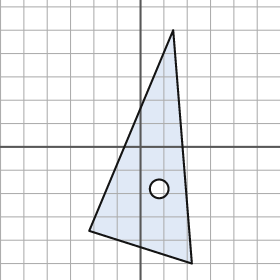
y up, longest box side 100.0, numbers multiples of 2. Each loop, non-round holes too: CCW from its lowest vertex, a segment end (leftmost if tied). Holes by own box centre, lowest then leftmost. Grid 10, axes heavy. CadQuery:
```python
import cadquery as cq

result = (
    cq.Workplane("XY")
    .moveTo(22.0, -50.0)
    .lineTo(14.0, 50.0)
    .lineTo(-22.0, -36.0)
    .close()
    .moveTo(8.0, -18.0)
    .circle(4.0)
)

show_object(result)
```